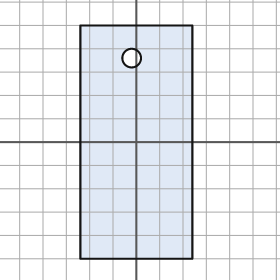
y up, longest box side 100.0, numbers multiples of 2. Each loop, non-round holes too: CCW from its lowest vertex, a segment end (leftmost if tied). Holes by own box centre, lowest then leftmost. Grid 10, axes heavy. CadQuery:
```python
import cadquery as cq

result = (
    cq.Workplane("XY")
    .moveTo(-24.0, -50.0)
    .lineTo(24.0, -50.0)
    .lineTo(24.0, 50.0)
    .lineTo(-24.0, 50.0)
    .close()
    .moveTo(-2.0, 36.0)
    .circle(4.0)
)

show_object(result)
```